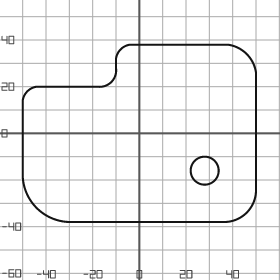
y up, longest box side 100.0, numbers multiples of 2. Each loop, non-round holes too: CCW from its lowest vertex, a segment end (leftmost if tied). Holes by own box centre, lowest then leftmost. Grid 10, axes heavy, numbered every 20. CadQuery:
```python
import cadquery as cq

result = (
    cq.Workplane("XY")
    .moveTo(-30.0, -38.0)
    .lineTo(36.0, -38.0)
    .threePointArc((46.0, -34.0), (50.0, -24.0))
    .lineTo(50.0, 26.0)
    .threePointArc((46.0, 34.0), (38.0, 38.0))
    .lineTo(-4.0, 38.0)
    .threePointArc((-8.0, 36.0), (-10.0, 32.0))
    .lineTo(-10.0, 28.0)
    .threePointArc((-12.0, 22.0), (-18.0, 20.0))
    .lineTo(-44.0, 20.0)
    .threePointArc((-48.0, 18.0), (-50.0, 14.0))
    .lineTo(-50.0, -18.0)
    .threePointArc((-44.0, -32.0), (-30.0, -38.0))
    .close()
    .moveTo(28.0, -16.0)
    .circle(6.0)
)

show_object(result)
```